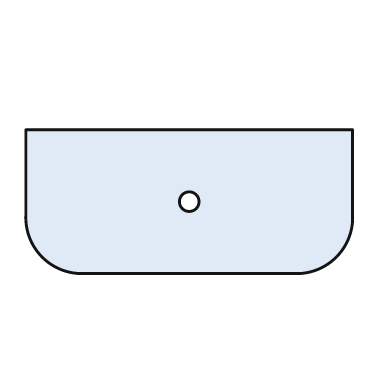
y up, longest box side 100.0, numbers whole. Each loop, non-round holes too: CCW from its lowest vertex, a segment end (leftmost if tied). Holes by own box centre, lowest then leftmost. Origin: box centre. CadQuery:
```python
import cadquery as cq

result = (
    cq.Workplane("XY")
    .moveTo(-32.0, -22.0)
    .lineTo(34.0, -22.0)
    .threePointArc((45.0, -17.0), (50.0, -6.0))
    .lineTo(50.0, 22.0)
    .lineTo(-50.0, 22.0)
    .lineTo(-50.0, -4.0)
    .threePointArc((-45.0, -17.0), (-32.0, -22.0))
    .close()
    .moveTo(0.0, 0.0)
    .circle(3.0)
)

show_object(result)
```